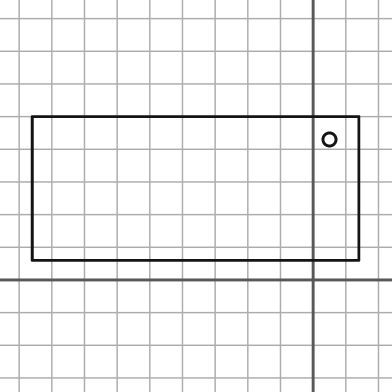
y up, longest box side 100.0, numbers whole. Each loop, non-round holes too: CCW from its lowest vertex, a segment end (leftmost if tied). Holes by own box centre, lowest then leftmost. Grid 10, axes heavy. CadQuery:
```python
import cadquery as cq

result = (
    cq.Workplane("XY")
    .moveTo(-86.0, 6.0)
    .lineTo(14.0, 6.0)
    .lineTo(14.0, 50.0)
    .lineTo(-86.0, 50.0)
    .close()
    .moveTo(5.0, 43.0)
    .circle(2.0)
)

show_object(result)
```